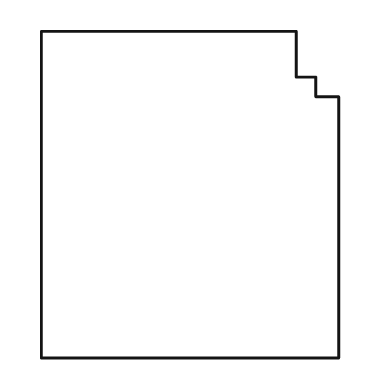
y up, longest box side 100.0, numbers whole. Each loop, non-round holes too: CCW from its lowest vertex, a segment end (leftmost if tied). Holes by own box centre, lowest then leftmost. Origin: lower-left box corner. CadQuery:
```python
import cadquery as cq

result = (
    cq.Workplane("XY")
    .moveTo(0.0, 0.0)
    .lineTo(91.0, 0.0)
    .lineTo(91.0, 80.0)
    .lineTo(84.0, 80.0)
    .lineTo(84.0, 86.0)
    .lineTo(78.0, 86.0)
    .lineTo(78.0, 100.0)
    .lineTo(0.0, 100.0)
    .close()
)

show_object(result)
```